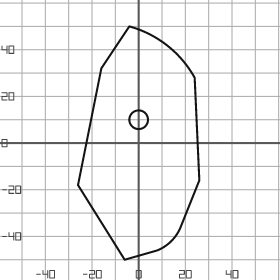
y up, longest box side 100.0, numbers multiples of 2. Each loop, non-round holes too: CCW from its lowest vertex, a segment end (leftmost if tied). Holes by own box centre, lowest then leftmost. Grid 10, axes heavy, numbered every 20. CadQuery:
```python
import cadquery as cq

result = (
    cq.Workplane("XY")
    .moveTo(-6.0, -50.0)
    .lineTo(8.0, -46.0)
    .threePointArc((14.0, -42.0), (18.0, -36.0))
    .lineTo(26.0, -16.0)
    .lineTo(24.0, 28.0)
    .threePointArc((12.0, 42.0), (-4.0, 50.0))
    .lineTo(-16.0, 32.0)
    .lineTo(-26.0, -18.0)
    .close()
    .moveTo(0.0, 10.0)
    .circle(4.0)
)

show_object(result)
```